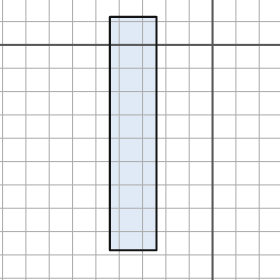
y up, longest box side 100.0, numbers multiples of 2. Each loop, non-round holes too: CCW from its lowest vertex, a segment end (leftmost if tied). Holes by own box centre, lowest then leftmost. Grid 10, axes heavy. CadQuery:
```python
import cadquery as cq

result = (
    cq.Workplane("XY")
    .moveTo(-44.0, -88.0)
    .lineTo(-24.0, -88.0)
    .lineTo(-24.0, 12.0)
    .lineTo(-44.0, 12.0)
    .close()
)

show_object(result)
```